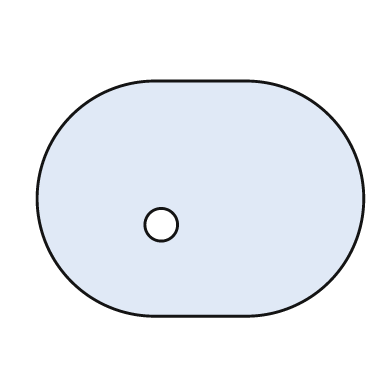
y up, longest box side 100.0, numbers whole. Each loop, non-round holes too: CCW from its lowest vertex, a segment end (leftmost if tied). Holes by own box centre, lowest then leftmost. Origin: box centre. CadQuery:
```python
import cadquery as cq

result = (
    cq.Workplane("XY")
    .moveTo(-14.0, -36.0)
    .lineTo(14.0, -36.0)
    .threePointArc((50.0, 0.0), (14.0, 36.0))
    .lineTo(-14.0, 36.0)
    .threePointArc((-50.0, 0.0), (-14.0, -36.0))
    .close()
    .moveTo(-12.0, -8.0)
    .circle(5.0)
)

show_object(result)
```